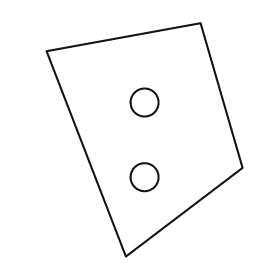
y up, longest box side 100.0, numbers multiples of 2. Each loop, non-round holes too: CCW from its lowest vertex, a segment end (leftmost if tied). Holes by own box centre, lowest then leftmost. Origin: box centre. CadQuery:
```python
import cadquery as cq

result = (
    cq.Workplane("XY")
    .moveTo(-8.0, -50.0)
    .lineTo(42.0, -12.0)
    .lineTo(24.0, 50.0)
    .lineTo(-42.0, 38.0)
    .close()
    .moveTo(0.0, -16.0)
    .circle(6.0)
    .moveTo(0.0, 16.0)
    .circle(6.0)
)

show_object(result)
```